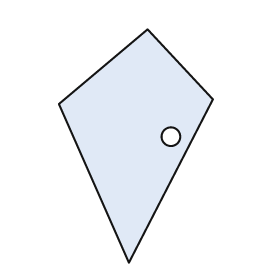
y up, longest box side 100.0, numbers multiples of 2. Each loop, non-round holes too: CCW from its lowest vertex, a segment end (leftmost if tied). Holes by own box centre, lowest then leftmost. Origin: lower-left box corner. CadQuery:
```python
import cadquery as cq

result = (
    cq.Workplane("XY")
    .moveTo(30.0, 0.0)
    .lineTo(66.0, 70.0)
    .lineTo(38.0, 100.0)
    .lineTo(0.0, 68.0)
    .close()
    .moveTo(48.0, 54.0)
    .circle(4.0)
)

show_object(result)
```